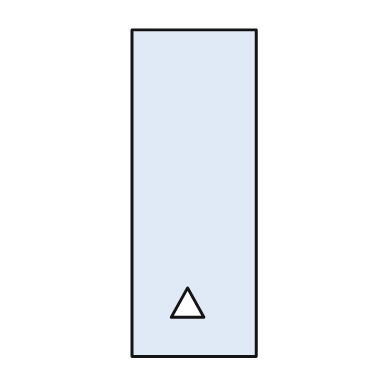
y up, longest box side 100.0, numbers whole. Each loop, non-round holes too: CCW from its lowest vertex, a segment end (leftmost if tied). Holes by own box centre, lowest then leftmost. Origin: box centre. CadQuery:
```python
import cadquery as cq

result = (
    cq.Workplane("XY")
    .moveTo(-19.0, -50.0)
    .lineTo(19.0, -50.0)
    .lineTo(19.0, 50.0)
    .lineTo(-19.0, 50.0)
    .close()
    .moveTo(-7.0, -38.0)
    .lineTo(3.0, -38.0)
    .lineTo(-2.0, -29.0)
    .close()
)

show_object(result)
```